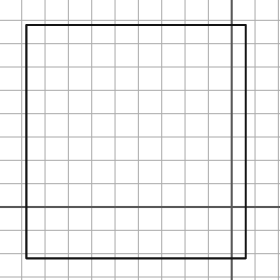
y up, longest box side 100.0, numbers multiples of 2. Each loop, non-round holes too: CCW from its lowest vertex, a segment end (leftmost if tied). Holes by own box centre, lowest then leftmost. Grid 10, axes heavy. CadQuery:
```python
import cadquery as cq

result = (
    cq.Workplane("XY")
    .moveTo(-88.0, -22.0)
    .lineTo(6.0, -22.0)
    .lineTo(6.0, 78.0)
    .lineTo(-88.0, 78.0)
    .close()
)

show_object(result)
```